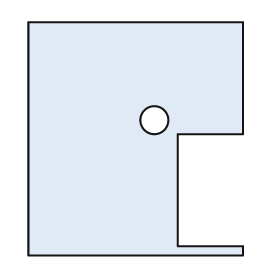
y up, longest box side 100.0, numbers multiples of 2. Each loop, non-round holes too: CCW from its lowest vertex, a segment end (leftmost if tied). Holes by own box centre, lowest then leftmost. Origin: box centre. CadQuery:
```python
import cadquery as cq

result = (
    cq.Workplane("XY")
    .moveTo(-46.0, -50.0)
    .lineTo(46.0, -50.0)
    .lineTo(46.0, -46.0)
    .lineTo(18.0, -46.0)
    .lineTo(18.0, 2.0)
    .lineTo(46.0, 2.0)
    .lineTo(46.0, 50.0)
    .lineTo(-46.0, 50.0)
    .close()
    .moveTo(8.0, 8.0)
    .circle(6.0)
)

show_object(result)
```